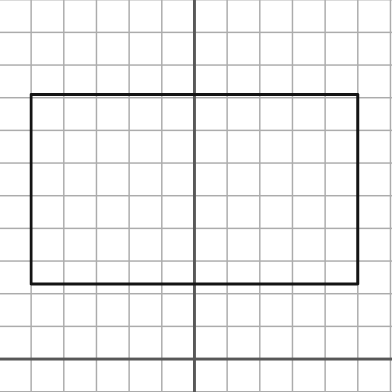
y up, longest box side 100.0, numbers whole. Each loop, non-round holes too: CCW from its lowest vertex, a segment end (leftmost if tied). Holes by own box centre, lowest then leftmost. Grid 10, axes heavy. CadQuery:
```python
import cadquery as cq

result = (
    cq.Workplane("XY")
    .moveTo(-50.0, 23.0)
    .lineTo(50.0, 23.0)
    .lineTo(50.0, 81.0)
    .lineTo(-50.0, 81.0)
    .close()
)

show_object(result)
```